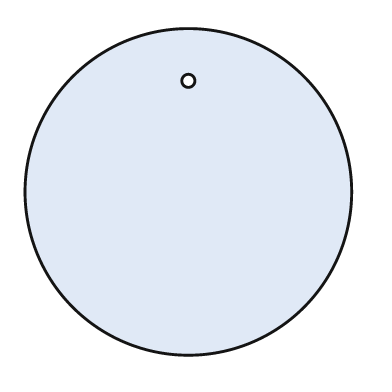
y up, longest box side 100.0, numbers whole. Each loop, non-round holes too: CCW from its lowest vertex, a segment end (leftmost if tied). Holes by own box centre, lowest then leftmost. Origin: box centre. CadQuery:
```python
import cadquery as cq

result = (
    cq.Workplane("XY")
    .moveTo(0.0, 0.0)
    .circle(50.0)
    .moveTo(0.0, 34.0)
    .circle(2.0)
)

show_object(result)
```